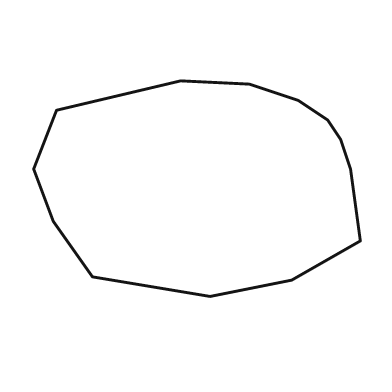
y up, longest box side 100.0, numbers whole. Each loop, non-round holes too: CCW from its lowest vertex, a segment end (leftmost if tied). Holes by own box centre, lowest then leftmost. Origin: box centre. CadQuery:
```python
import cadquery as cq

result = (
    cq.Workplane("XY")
    .moveTo(4.0, -33.0)
    .lineTo(29.0, -28.0)
    .lineTo(50.0, -16.0)
    .lineTo(47.0, 6.0)
    .lineTo(44.0, 15.0)
    .lineTo(40.0, 21.0)
    .lineTo(31.0, 27.0)
    .lineTo(16.0, 32.0)
    .lineTo(-5.0, 33.0)
    .lineTo(-43.0, 24.0)
    .lineTo(-50.0, 6.0)
    .lineTo(-44.0, -10.0)
    .lineTo(-32.0, -27.0)
    .close()
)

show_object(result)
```